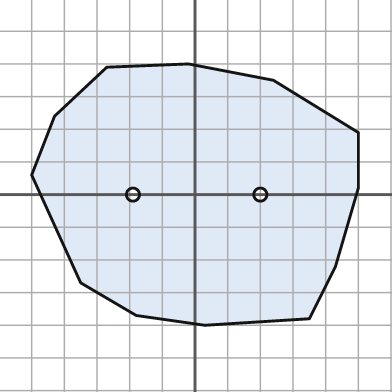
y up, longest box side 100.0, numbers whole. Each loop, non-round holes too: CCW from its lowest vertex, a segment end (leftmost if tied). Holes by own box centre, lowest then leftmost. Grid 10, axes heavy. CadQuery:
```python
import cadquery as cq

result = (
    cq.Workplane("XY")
    .moveTo(3.0, -40.0)
    .lineTo(35.0, -38.0)
    .lineTo(43.0, -22.0)
    .lineTo(50.0, 2.0)
    .lineTo(50.0, 19.0)
    .lineTo(24.0, 35.0)
    .lineTo(-2.0, 40.0)
    .lineTo(-27.0, 39.0)
    .lineTo(-43.0, 24.0)
    .lineTo(-50.0, 6.0)
    .lineTo(-35.0, -27.0)
    .lineTo(-18.0, -37.0)
    .close()
    .moveTo(-19.0, 0.0)
    .circle(2.0)
    .moveTo(20.0, 0.0)
    .circle(2.0)
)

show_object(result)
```